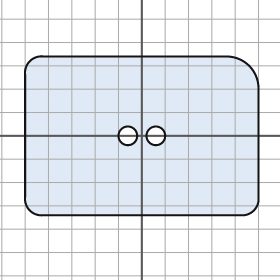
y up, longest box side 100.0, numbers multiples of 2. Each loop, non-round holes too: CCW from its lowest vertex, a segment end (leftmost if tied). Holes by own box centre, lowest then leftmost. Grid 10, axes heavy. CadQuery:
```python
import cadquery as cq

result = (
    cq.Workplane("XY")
    .moveTo(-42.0, -34.0)
    .lineTo(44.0, -34.0)
    .threePointArc((48.0, -32.0), (50.0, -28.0))
    .lineTo(50.0, 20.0)
    .threePointArc((46.0, 30.0), (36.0, 34.0))
    .lineTo(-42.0, 34.0)
    .threePointArc((-48.0, 32.0), (-50.0, 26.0))
    .lineTo(-50.0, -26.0)
    .threePointArc((-48.0, -32.0), (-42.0, -34.0))
    .close()
    .moveTo(-6.0, 0.0)
    .circle(4.0)
    .moveTo(6.0, 0.0)
    .circle(4.0)
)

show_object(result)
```